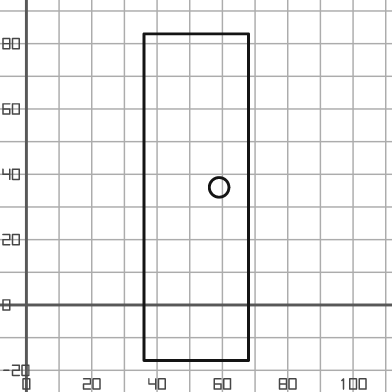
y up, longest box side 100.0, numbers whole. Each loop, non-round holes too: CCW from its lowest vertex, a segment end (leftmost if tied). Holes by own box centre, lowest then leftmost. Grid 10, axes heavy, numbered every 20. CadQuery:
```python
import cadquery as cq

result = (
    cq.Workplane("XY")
    .moveTo(36.0, -17.0)
    .lineTo(68.0, -17.0)
    .lineTo(68.0, 83.0)
    .lineTo(36.0, 83.0)
    .close()
    .moveTo(59.0, 36.0)
    .circle(3.0)
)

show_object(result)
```